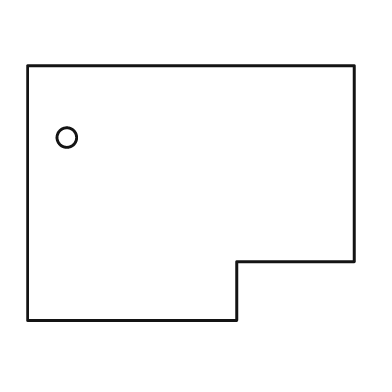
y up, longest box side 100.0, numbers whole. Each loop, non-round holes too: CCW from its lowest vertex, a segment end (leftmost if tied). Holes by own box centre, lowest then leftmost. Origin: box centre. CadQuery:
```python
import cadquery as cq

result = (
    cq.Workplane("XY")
    .moveTo(-50.0, -39.0)
    .lineTo(14.0, -39.0)
    .lineTo(14.0, -21.0)
    .lineTo(50.0, -21.0)
    .lineTo(50.0, 39.0)
    .lineTo(-50.0, 39.0)
    .close()
    .moveTo(-38.0, 17.0)
    .circle(3.0)
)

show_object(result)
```